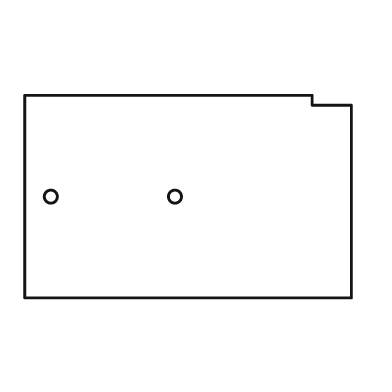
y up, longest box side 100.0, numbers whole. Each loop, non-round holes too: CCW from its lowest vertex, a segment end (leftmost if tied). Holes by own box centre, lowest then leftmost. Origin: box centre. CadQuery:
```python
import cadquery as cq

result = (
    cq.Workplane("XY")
    .moveTo(-50.0, -31.0)
    .lineTo(50.0, -31.0)
    .lineTo(50.0, 28.0)
    .lineTo(38.0, 28.0)
    .lineTo(38.0, 31.0)
    .lineTo(-50.0, 31.0)
    .close()
    .moveTo(-42.0, 0.0)
    .circle(2.0)
    .moveTo(-4.0, 0.0)
    .circle(2.0)
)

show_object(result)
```